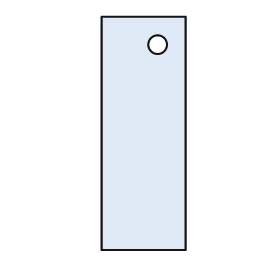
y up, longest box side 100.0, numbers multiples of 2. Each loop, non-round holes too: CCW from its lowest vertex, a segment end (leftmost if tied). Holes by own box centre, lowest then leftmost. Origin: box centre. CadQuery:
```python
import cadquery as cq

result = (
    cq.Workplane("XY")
    .moveTo(-18.0, -50.0)
    .lineTo(18.0, -50.0)
    .lineTo(18.0, 50.0)
    .lineTo(-18.0, 50.0)
    .close()
    .moveTo(6.0, 38.0)
    .circle(4.0)
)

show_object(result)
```